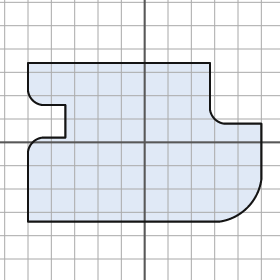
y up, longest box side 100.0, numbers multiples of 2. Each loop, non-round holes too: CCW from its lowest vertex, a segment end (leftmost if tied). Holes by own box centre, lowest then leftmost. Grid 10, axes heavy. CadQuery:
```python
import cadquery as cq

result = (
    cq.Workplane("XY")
    .moveTo(-50.0, -34.0)
    .lineTo(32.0, -34.0)
    .threePointArc((44.0, -28.0), (50.0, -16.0))
    .lineTo(50.0, 8.0)
    .lineTo(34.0, 8.0)
    .threePointArc((30.0, 10.0), (28.0, 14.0))
    .lineTo(28.0, 34.0)
    .lineTo(-50.0, 34.0)
    .lineTo(-50.0, 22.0)
    .threePointArc((-48.0, 18.0), (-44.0, 16.0))
    .lineTo(-34.0, 16.0)
    .lineTo(-34.0, 2.0)
    .lineTo(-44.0, 2.0)
    .threePointArc((-48.0, 0.0), (-50.0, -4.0))
    .close()
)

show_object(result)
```